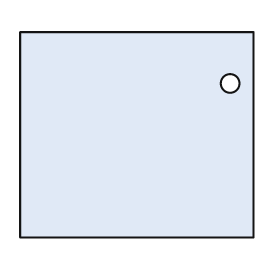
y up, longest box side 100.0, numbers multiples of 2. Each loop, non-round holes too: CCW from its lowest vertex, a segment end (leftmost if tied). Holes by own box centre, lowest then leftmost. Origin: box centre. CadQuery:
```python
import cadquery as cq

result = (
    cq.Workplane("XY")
    .moveTo(-50.0, -44.0)
    .lineTo(50.0, -44.0)
    .lineTo(50.0, 44.0)
    .lineTo(-50.0, 44.0)
    .close()
    .moveTo(40.0, 22.0)
    .circle(4.0)
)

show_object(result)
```